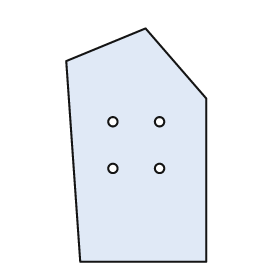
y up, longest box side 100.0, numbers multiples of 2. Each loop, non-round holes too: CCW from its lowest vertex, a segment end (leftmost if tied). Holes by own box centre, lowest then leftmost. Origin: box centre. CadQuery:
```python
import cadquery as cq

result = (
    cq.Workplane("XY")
    .moveTo(-24.0, -50.0)
    .lineTo(30.0, -50.0)
    .lineTo(30.0, 20.0)
    .lineTo(4.0, 50.0)
    .lineTo(-30.0, 36.0)
    .close()
    .moveTo(-10.0, -10.0)
    .circle(2.0)
    .moveTo(10.0, -10.0)
    .circle(2.0)
    .moveTo(-10.0, 10.0)
    .circle(2.0)
    .moveTo(10.0, 10.0)
    .circle(2.0)
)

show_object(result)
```